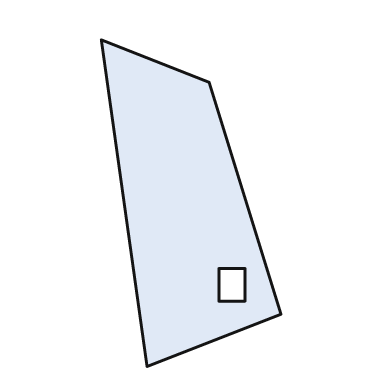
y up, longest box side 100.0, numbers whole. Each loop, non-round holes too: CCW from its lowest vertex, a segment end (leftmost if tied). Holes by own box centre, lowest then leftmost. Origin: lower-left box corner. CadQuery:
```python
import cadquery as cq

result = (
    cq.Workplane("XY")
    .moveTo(14.0, 0.0)
    .lineTo(55.0, 16.0)
    .lineTo(33.0, 87.0)
    .lineTo(0.0, 100.0)
    .close()
    .moveTo(36.0, 20.0)
    .lineTo(44.0, 20.0)
    .lineTo(44.0, 30.0)
    .lineTo(36.0, 30.0)
    .close()
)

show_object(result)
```